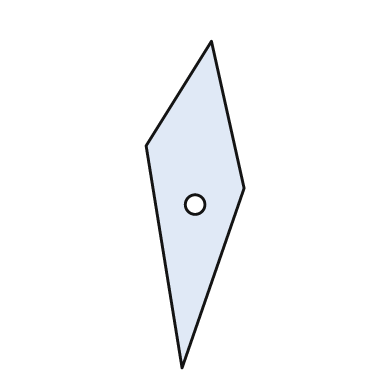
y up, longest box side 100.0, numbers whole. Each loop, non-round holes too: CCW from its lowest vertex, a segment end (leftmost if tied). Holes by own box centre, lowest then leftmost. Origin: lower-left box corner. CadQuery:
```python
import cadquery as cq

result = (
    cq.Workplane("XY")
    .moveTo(11.0, 0.0)
    .lineTo(30.0, 55.0)
    .lineTo(20.0, 100.0)
    .lineTo(0.0, 68.0)
    .close()
    .moveTo(15.0, 50.0)
    .circle(3.0)
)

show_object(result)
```